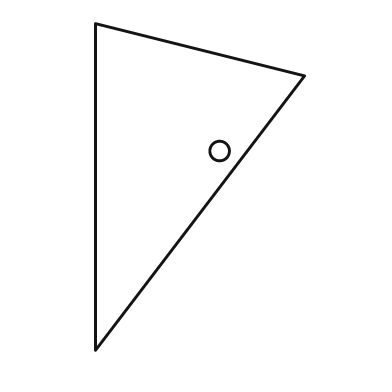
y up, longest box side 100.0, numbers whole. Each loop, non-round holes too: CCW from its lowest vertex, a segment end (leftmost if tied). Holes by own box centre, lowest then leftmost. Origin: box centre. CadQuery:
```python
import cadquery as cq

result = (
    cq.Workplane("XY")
    .moveTo(-32.0, -50.0)
    .lineTo(32.0, 34.0)
    .lineTo(-32.0, 50.0)
    .close()
    .moveTo(6.0, 11.0)
    .circle(3.0)
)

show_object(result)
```